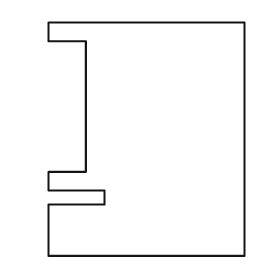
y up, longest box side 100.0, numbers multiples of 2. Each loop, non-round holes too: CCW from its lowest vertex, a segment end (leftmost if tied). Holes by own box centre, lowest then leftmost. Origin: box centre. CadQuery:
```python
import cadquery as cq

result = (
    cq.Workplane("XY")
    .moveTo(-42.0, -50.0)
    .lineTo(42.0, -50.0)
    .lineTo(42.0, 50.0)
    .lineTo(-42.0, 50.0)
    .lineTo(-42.0, 42.0)
    .lineTo(-26.0, 42.0)
    .lineTo(-26.0, -14.0)
    .lineTo(-42.0, -14.0)
    .lineTo(-42.0, -22.0)
    .lineTo(-18.0, -22.0)
    .lineTo(-18.0, -28.0)
    .lineTo(-42.0, -28.0)
    .close()
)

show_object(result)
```